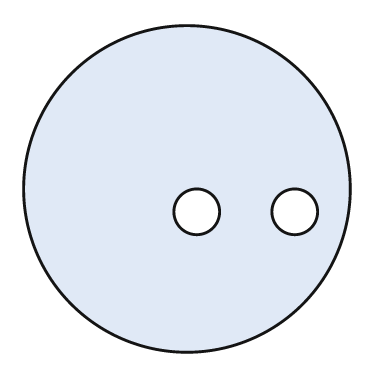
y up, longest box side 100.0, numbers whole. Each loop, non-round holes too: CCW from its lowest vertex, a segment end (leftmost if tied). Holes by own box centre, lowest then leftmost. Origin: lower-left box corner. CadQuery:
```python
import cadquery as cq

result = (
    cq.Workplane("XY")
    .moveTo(50.0, 50.0)
    .circle(50.0)
    .moveTo(53.0, 43.0)
    .circle(7.0)
    .moveTo(83.0, 43.0)
    .circle(7.0)
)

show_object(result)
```